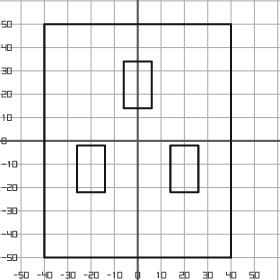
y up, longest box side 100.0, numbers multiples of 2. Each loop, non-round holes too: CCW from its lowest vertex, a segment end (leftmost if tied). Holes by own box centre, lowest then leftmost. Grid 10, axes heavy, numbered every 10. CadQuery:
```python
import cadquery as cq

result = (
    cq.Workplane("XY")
    .moveTo(-40.0, -50.0)
    .lineTo(40.0, -50.0)
    .lineTo(40.0, 50.0)
    .lineTo(-40.0, 50.0)
    .close()
    .moveTo(-26.0, -22.0)
    .lineTo(-14.0, -22.0)
    .lineTo(-14.0, -2.0)
    .lineTo(-26.0, -2.0)
    .close()
    .moveTo(14.0, -22.0)
    .lineTo(26.0, -22.0)
    .lineTo(26.0, -2.0)
    .lineTo(14.0, -2.0)
    .close()
    .moveTo(-6.0, 14.0)
    .lineTo(6.0, 14.0)
    .lineTo(6.0, 34.0)
    .lineTo(-6.0, 34.0)
    .close()
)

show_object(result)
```